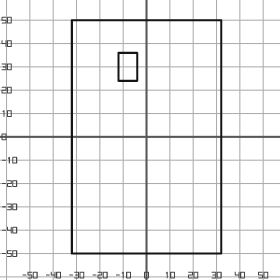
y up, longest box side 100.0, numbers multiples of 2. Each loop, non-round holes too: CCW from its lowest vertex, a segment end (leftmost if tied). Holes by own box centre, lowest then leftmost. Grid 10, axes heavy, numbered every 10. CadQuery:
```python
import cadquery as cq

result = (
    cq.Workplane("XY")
    .moveTo(-32.0, -50.0)
    .lineTo(32.0, -50.0)
    .lineTo(32.0, 50.0)
    .lineTo(-32.0, 50.0)
    .close()
    .moveTo(-12.0, 24.0)
    .lineTo(-4.0, 24.0)
    .lineTo(-4.0, 36.0)
    .lineTo(-12.0, 36.0)
    .close()
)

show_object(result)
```